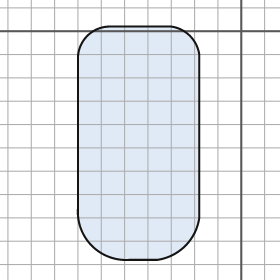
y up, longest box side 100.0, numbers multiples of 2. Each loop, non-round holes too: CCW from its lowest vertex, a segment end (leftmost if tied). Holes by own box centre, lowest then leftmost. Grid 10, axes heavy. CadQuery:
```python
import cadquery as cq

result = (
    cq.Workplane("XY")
    .moveTo(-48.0, -98.0)
    .lineTo(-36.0, -98.0)
    .threePointArc((-24.0, -92.0), (-18.0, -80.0))
    .lineTo(-18.0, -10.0)
    .threePointArc((-22.0, -2.0), (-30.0, 2.0))
    .lineTo(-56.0, 2.0)
    .threePointArc((-66.0, -2.0), (-70.0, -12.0))
    .lineTo(-70.0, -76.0)
    .threePointArc((-64.0, -92.0), (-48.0, -98.0))
    .close()
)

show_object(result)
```